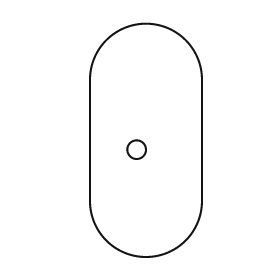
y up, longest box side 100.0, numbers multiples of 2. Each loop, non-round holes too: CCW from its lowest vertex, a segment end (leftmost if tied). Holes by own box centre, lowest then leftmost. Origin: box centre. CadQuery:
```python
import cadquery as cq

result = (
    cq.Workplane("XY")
    .moveTo(-24.0, -26.0)
    .threePointArc((0.0, -50.0), (24.0, -26.0))
    .lineTo(24.0, 26.0)
    .threePointArc((0.0, 50.0), (-24.0, 26.0))
    .close()
    .moveTo(-4.0, -4.0)
    .circle(4.0)
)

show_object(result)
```